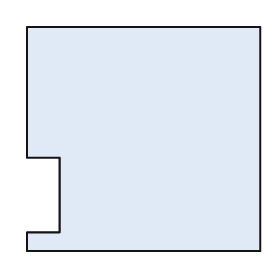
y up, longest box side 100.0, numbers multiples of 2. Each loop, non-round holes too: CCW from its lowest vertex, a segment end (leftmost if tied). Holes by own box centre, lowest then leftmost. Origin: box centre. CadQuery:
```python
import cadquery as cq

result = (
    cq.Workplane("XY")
    .moveTo(-50.0, -48.0)
    .lineTo(50.0, -48.0)
    .lineTo(50.0, 48.0)
    .lineTo(-50.0, 48.0)
    .lineTo(-50.0, -8.0)
    .lineTo(-36.0, -8.0)
    .lineTo(-36.0, -40.0)
    .lineTo(-50.0, -40.0)
    .close()
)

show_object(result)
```